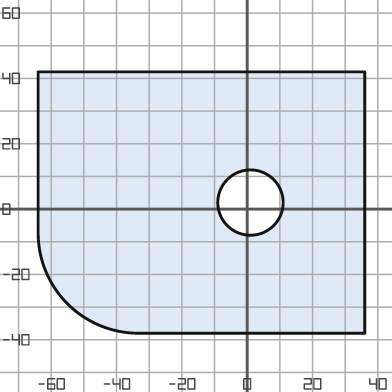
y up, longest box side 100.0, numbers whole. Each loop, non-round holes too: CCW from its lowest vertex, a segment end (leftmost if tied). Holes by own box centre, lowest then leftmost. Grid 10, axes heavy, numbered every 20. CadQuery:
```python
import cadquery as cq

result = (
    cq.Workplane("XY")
    .moveTo(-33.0, -38.0)
    .lineTo(36.0, -38.0)
    .lineTo(36.0, 42.0)
    .lineTo(-64.0, 42.0)
    .lineTo(-64.0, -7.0)
    .threePointArc((-55.0, -29.0), (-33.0, -38.0))
    .close()
    .moveTo(1.0, 2.0)
    .circle(10.0)
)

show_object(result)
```